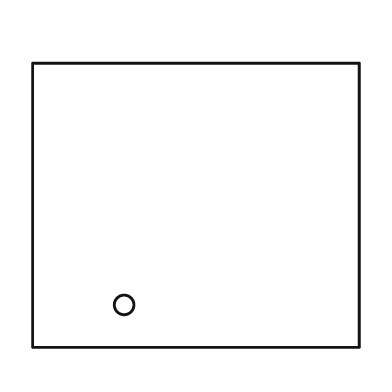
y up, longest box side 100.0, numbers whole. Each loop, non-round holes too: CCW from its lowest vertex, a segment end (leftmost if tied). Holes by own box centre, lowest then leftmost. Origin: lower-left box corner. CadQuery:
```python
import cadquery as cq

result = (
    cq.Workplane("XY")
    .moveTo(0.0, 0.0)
    .lineTo(100.0, 0.0)
    .lineTo(100.0, 87.0)
    .lineTo(0.0, 87.0)
    .close()
    .moveTo(28.0, 13.0)
    .circle(3.0)
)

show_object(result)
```